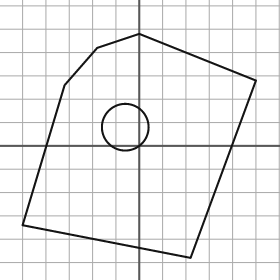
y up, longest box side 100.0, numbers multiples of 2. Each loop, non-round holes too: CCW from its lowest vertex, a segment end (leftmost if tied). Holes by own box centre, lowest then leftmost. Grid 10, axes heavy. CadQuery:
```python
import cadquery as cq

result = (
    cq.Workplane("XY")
    .moveTo(22.0, -48.0)
    .lineTo(50.0, 28.0)
    .lineTo(0.0, 48.0)
    .lineTo(-18.0, 42.0)
    .lineTo(-32.0, 26.0)
    .lineTo(-50.0, -34.0)
    .close()
    .moveTo(-6.0, 8.0)
    .circle(10.0)
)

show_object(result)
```